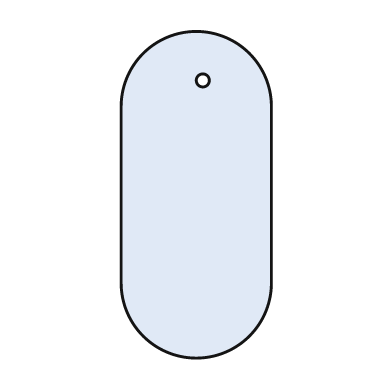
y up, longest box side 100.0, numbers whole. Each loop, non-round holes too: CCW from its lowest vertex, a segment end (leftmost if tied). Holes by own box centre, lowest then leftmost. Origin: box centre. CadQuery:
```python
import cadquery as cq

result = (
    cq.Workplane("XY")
    .moveTo(-23.0, -27.0)
    .threePointArc((0.0, -50.0), (23.0, -27.0))
    .lineTo(23.0, 27.0)
    .threePointArc((0.0, 50.0), (-23.0, 27.0))
    .close()
    .moveTo(2.0, 35.0)
    .circle(2.0)
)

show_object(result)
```